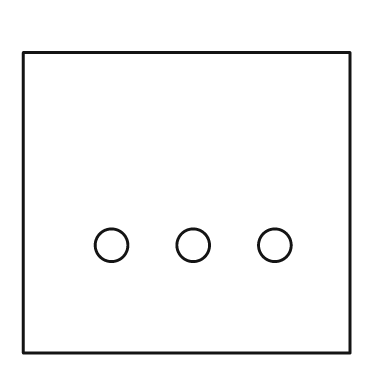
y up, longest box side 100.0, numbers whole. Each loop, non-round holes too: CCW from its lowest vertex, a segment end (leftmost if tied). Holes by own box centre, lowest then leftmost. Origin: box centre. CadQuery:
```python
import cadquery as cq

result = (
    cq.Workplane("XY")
    .moveTo(-50.0, -46.0)
    .lineTo(50.0, -46.0)
    .lineTo(50.0, 46.0)
    .lineTo(-50.0, 46.0)
    .close()
    .moveTo(-23.0, -13.0)
    .circle(5.0)
    .moveTo(2.0, -13.0)
    .circle(5.0)
    .moveTo(27.0, -13.0)
    .circle(5.0)
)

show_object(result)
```